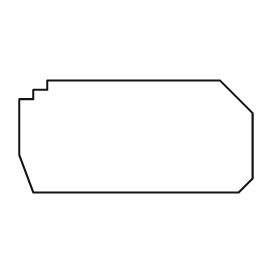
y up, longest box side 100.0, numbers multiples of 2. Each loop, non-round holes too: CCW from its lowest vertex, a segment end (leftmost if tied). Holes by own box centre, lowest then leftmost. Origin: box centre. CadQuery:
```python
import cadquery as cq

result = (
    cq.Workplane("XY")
    .moveTo(-44.0, -24.0)
    .lineTo(44.0, -24.0)
    .lineTo(50.0, -18.0)
    .lineTo(50.0, 10.0)
    .lineTo(36.0, 24.0)
    .lineTo(-38.0, 24.0)
    .lineTo(-38.0, 20.0)
    .lineTo(-44.0, 20.0)
    .lineTo(-44.0, 16.0)
    .lineTo(-50.0, 16.0)
    .lineTo(-50.0, -8.0)
    .close()
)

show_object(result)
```